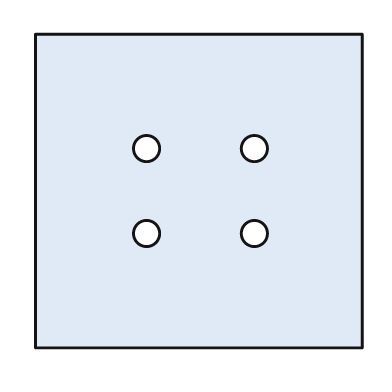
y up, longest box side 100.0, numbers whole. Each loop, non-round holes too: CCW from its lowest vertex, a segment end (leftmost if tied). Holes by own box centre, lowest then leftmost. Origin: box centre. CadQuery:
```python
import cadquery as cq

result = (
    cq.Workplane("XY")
    .moveTo(-50.0, -48.0)
    .lineTo(50.0, -48.0)
    .lineTo(50.0, 48.0)
    .lineTo(-50.0, 48.0)
    .close()
    .moveTo(-16.0, -13.0)
    .circle(4.0)
    .moveTo(17.0, -13.0)
    .circle(4.0)
    .moveTo(-16.0, 13.0)
    .circle(4.0)
    .moveTo(17.0, 13.0)
    .circle(4.0)
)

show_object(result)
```